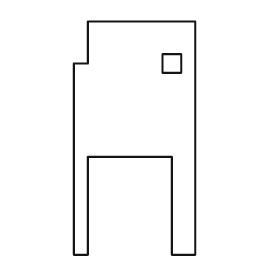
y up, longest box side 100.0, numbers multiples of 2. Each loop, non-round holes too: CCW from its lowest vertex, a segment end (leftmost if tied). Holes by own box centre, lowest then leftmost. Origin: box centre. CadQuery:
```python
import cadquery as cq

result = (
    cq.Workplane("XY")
    .moveTo(-26.0, -50.0)
    .lineTo(-20.0, -50.0)
    .lineTo(-20.0, -8.0)
    .lineTo(16.0, -8.0)
    .lineTo(16.0, -50.0)
    .lineTo(26.0, -50.0)
    .lineTo(26.0, 50.0)
    .lineTo(-20.0, 50.0)
    .lineTo(-20.0, 32.0)
    .lineTo(-26.0, 32.0)
    .close()
    .moveTo(12.0, 28.0)
    .lineTo(20.0, 28.0)
    .lineTo(20.0, 36.0)
    .lineTo(12.0, 36.0)
    .close()
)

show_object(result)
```